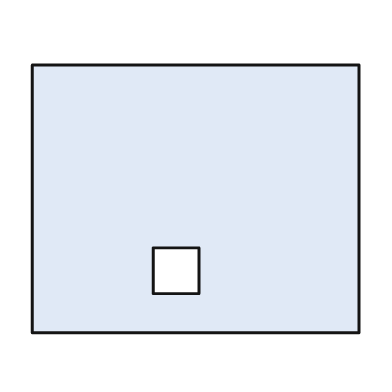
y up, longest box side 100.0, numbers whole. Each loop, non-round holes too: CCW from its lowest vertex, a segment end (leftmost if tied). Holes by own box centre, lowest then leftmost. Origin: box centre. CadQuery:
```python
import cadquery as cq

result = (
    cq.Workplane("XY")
    .moveTo(-50.0, -41.0)
    .lineTo(50.0, -41.0)
    .lineTo(50.0, 41.0)
    .lineTo(-50.0, 41.0)
    .close()
    .moveTo(-13.0, -29.0)
    .lineTo(1.0, -29.0)
    .lineTo(1.0, -15.0)
    .lineTo(-13.0, -15.0)
    .close()
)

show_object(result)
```